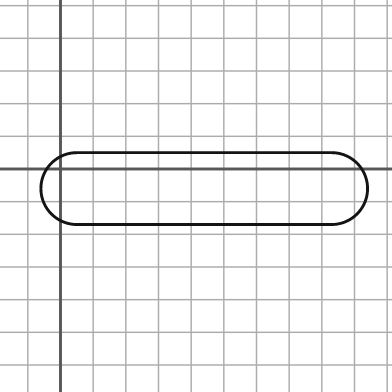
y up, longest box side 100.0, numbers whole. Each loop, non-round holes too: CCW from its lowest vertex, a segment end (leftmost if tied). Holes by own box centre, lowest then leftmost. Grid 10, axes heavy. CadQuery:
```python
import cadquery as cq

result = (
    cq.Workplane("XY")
    .moveTo(5.0, -17.0)
    .lineTo(83.0, -17.0)
    .threePointArc((94.0, -6.0), (83.0, 5.0))
    .lineTo(5.0, 5.0)
    .threePointArc((-6.0, -6.0), (5.0, -17.0))
    .close()
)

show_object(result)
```